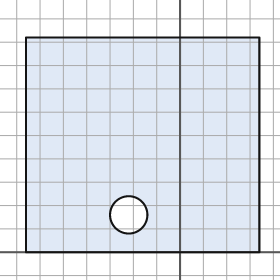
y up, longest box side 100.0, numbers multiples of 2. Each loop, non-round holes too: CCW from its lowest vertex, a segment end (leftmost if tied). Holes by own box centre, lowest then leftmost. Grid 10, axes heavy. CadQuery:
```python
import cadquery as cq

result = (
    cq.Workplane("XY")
    .moveTo(-66.0, 0.0)
    .lineTo(34.0, 0.0)
    .lineTo(34.0, 92.0)
    .lineTo(-66.0, 92.0)
    .close()
    .moveTo(-22.0, 16.0)
    .circle(8.0)
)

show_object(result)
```